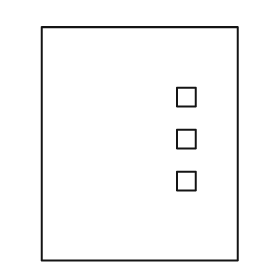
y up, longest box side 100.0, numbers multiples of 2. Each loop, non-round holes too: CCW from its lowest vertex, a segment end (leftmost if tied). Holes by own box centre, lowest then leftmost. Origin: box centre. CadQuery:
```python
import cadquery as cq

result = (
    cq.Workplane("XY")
    .moveTo(-42.0, -50.0)
    .lineTo(42.0, -50.0)
    .lineTo(42.0, 50.0)
    .lineTo(-42.0, 50.0)
    .close()
    .moveTo(16.0, -20.0)
    .lineTo(24.0, -20.0)
    .lineTo(24.0, -12.0)
    .lineTo(16.0, -12.0)
    .close()
    .moveTo(16.0, -2.0)
    .lineTo(24.0, -2.0)
    .lineTo(24.0, 6.0)
    .lineTo(16.0, 6.0)
    .close()
    .moveTo(16.0, 16.0)
    .lineTo(24.0, 16.0)
    .lineTo(24.0, 24.0)
    .lineTo(16.0, 24.0)
    .close()
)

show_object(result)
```